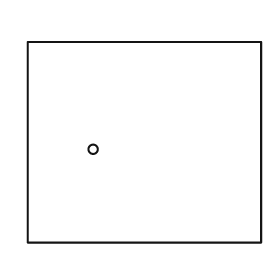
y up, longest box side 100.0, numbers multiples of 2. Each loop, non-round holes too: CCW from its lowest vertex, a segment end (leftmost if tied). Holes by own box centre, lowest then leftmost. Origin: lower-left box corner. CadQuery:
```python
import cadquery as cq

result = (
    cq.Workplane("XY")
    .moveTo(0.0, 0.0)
    .lineTo(100.0, 0.0)
    .lineTo(100.0, 86.0)
    .lineTo(0.0, 86.0)
    .close()
    .moveTo(28.0, 40.0)
    .circle(2.0)
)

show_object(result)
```